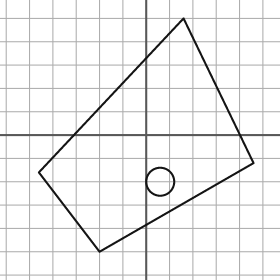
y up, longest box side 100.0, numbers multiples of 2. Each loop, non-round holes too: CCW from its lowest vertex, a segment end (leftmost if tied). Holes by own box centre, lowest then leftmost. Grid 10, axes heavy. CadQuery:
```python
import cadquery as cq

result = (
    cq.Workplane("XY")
    .moveTo(-20.0, -50.0)
    .lineTo(46.0, -12.0)
    .lineTo(16.0, 50.0)
    .lineTo(-46.0, -16.0)
    .close()
    .moveTo(6.0, -20.0)
    .circle(6.0)
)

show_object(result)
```